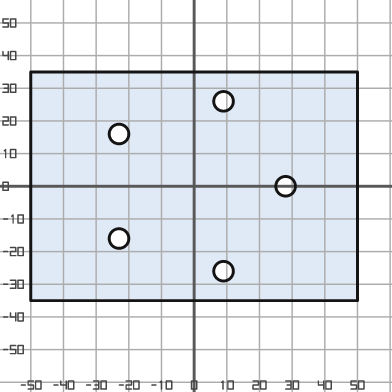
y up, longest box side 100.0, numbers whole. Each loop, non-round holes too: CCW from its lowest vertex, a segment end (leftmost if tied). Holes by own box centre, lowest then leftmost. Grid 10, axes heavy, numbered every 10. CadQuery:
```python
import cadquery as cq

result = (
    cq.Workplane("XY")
    .moveTo(-50.0, -35.0)
    .lineTo(50.0, -35.0)
    .lineTo(50.0, 35.0)
    .lineTo(-50.0, 35.0)
    .close()
    .moveTo(9.0, -26.0)
    .circle(3.0)
    .moveTo(-23.0, -16.0)
    .circle(3.0)
    .moveTo(28.0, 0.0)
    .circle(3.0)
    .moveTo(-23.0, 16.0)
    .circle(3.0)
    .moveTo(9.0, 26.0)
    .circle(3.0)
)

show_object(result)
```